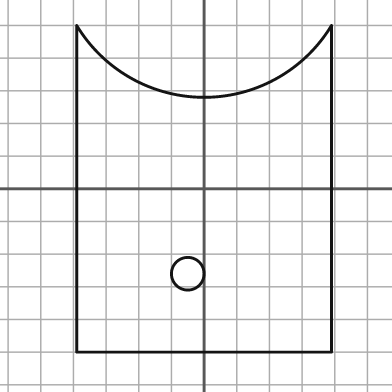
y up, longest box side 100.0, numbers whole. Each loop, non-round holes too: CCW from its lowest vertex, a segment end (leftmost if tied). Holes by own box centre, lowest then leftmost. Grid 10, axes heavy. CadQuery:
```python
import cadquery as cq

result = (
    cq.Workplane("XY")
    .moveTo(-39.0, -50.0)
    .lineTo(39.0, -50.0)
    .lineTo(39.0, 50.0)
    .threePointArc((0.0, 28.0), (-39.0, 50.0))
    .close()
    .moveTo(-5.0, -26.0)
    .circle(5.0)
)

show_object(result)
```